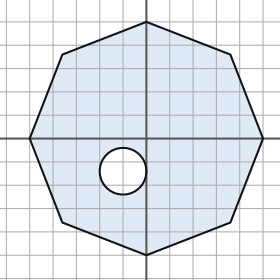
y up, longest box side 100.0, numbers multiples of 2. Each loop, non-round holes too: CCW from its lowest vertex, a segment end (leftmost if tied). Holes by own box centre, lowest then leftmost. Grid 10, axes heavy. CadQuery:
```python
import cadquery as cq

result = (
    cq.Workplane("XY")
    .moveTo(0.0, -50.0)
    .lineTo(36.0, -36.0)
    .lineTo(50.0, 0.0)
    .lineTo(36.0, 36.0)
    .lineTo(0.0, 50.0)
    .lineTo(-36.0, 36.0)
    .lineTo(-50.0, 0.0)
    .lineTo(-36.0, -36.0)
    .close()
    .moveTo(-10.0, -14.0)
    .circle(10.0)
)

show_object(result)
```